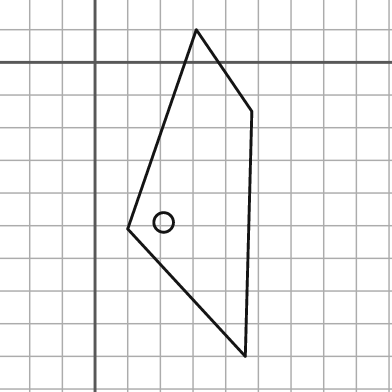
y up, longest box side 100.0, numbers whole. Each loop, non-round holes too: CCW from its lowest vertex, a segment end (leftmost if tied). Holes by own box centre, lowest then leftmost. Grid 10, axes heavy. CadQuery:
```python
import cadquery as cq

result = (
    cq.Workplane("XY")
    .moveTo(46.0, -90.0)
    .lineTo(48.0, -15.0)
    .lineTo(31.0, 10.0)
    .lineTo(10.0, -51.0)
    .close()
    .moveTo(21.0, -49.0)
    .circle(3.0)
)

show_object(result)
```